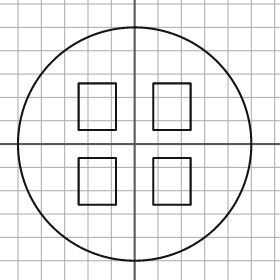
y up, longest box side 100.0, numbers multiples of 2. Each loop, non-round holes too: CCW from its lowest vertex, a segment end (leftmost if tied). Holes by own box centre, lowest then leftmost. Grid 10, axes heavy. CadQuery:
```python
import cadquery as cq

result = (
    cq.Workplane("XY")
    .moveTo(0.0, 0.0)
    .circle(50.0)
    .moveTo(-24.0, -26.0)
    .lineTo(-8.0, -26.0)
    .lineTo(-8.0, -6.0)
    .lineTo(-24.0, -6.0)
    .close()
    .moveTo(8.0, -26.0)
    .lineTo(24.0, -26.0)
    .lineTo(24.0, -6.0)
    .lineTo(8.0, -6.0)
    .close()
    .moveTo(-24.0, 6.0)
    .lineTo(-8.0, 6.0)
    .lineTo(-8.0, 26.0)
    .lineTo(-24.0, 26.0)
    .close()
    .moveTo(8.0, 6.0)
    .lineTo(24.0, 6.0)
    .lineTo(24.0, 26.0)
    .lineTo(8.0, 26.0)
    .close()
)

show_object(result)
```